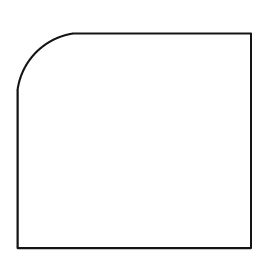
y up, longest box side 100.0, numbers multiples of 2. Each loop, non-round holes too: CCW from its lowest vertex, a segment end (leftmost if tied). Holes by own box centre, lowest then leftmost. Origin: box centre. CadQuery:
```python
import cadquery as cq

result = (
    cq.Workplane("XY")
    .moveTo(-50.0, -46.0)
    .lineTo(50.0, -46.0)
    .lineTo(50.0, 46.0)
    .lineTo(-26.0, 46.0)
    .threePointArc((-42.0, 38.0), (-50.0, 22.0))
    .close()
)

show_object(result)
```